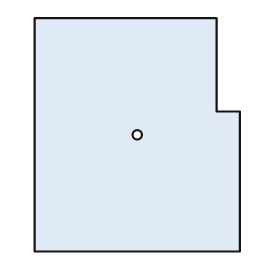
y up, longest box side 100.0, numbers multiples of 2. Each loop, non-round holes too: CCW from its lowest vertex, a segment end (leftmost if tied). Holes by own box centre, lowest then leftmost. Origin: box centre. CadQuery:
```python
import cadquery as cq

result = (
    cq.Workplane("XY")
    .moveTo(-44.0, -50.0)
    .lineTo(44.0, -50.0)
    .lineTo(44.0, 10.0)
    .lineTo(34.0, 10.0)
    .lineTo(34.0, 50.0)
    .lineTo(-44.0, 50.0)
    .close()
    .moveTo(0.0, 0.0)
    .circle(2.0)
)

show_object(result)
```